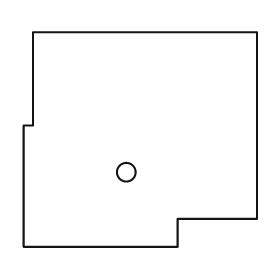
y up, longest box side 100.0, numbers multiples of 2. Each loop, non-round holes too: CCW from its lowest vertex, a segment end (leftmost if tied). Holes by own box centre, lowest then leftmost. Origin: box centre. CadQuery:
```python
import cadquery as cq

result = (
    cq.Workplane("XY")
    .moveTo(-50.0, -46.0)
    .lineTo(16.0, -46.0)
    .lineTo(16.0, -34.0)
    .lineTo(50.0, -34.0)
    .lineTo(50.0, 46.0)
    .lineTo(-46.0, 46.0)
    .lineTo(-46.0, 6.0)
    .lineTo(-50.0, 6.0)
    .close()
    .moveTo(-6.0, -14.0)
    .circle(4.0)
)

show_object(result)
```